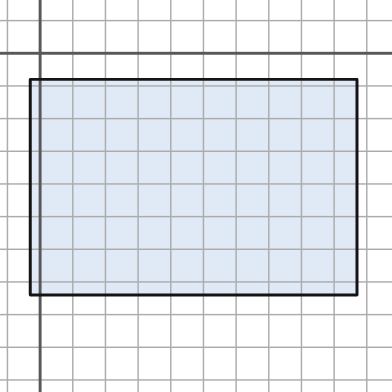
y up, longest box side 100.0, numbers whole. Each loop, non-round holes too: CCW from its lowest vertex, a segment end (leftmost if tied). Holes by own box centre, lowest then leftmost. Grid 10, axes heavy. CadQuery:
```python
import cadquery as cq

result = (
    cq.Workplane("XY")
    .moveTo(-3.0, -74.0)
    .lineTo(97.0, -74.0)
    .lineTo(97.0, -8.0)
    .lineTo(-3.0, -8.0)
    .close()
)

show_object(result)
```